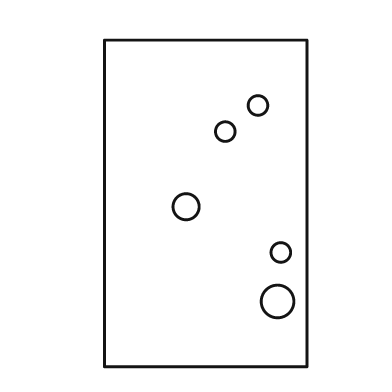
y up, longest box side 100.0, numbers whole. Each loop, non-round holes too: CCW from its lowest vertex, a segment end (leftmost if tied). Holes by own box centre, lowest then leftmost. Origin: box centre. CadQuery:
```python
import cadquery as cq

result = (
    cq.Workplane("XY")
    .moveTo(-31.0, -50.0)
    .lineTo(31.0, -50.0)
    .lineTo(31.0, 50.0)
    .lineTo(-31.0, 50.0)
    .close()
    .moveTo(22.0, -30.0)
    .circle(5.0)
    .moveTo(23.0, -15.0)
    .circle(3.0)
    .moveTo(-6.0, -1.0)
    .circle(4.0)
    .moveTo(6.0, 22.0)
    .circle(3.0)
    .moveTo(16.0, 30.0)
    .circle(3.0)
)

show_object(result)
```